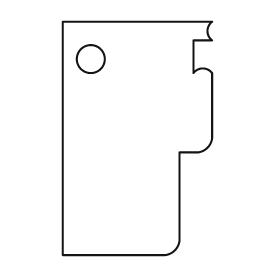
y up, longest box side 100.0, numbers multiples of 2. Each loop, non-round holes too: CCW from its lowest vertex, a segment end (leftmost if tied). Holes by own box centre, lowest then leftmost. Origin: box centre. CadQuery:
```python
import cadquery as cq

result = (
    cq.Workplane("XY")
    .moveTo(-32.0, -50.0)
    .lineTo(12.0, -50.0)
    .threePointArc((16.0, -48.0), (18.0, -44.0))
    .lineTo(18.0, -6.0)
    .lineTo(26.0, -6.0)
    .threePointArc((30.0, -4.0), (32.0, 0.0))
    .lineTo(32.0, 28.0)
    .threePointArc((28.0, 30.0), (24.0, 28.0))
    .lineTo(24.0, 42.0)
    .lineTo(32.0, 42.0)
    .threePointArc((30.0, 46.0), (32.0, 50.0))
    .lineTo(-32.0, 50.0)
    .close()
    .moveTo(-20.0, 34.0)
    .circle(6.0)
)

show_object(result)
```